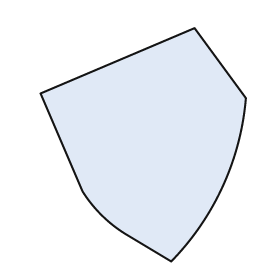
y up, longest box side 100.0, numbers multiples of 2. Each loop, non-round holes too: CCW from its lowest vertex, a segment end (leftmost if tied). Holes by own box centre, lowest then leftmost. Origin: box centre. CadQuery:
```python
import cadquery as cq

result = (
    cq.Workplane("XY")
    .moveTo(12.0, -50.0)
    .threePointArc((34.0, -18.0), (44.0, 20.0))
    .lineTo(22.0, 50.0)
    .lineTo(-44.0, 22.0)
    .lineTo(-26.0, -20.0)
    .threePointArc((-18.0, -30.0), (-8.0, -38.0))
    .close()
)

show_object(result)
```